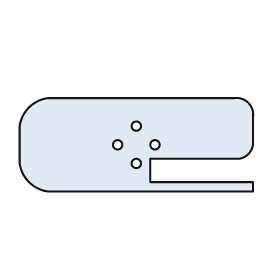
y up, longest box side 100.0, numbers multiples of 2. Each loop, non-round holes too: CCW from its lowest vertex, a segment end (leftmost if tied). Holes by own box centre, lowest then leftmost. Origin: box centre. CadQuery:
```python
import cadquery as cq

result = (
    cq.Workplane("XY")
    .moveTo(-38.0, -20.0)
    .lineTo(50.0, -20.0)
    .lineTo(50.0, -16.0)
    .lineTo(6.0, -16.0)
    .lineTo(6.0, -6.0)
    .lineTo(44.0, -6.0)
    .threePointArc((48.0, -4.0), (50.0, 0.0))
    .lineTo(50.0, 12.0)
    .threePointArc((48.0, 18.0), (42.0, 20.0))
    .lineTo(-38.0, 20.0)
    .threePointArc((-46.0, 16.0), (-50.0, 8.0))
    .lineTo(-50.0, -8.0)
    .threePointArc((-46.0, -16.0), (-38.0, -20.0))
    .close()
    .moveTo(0.0, -8.0)
    .circle(2.0)
    .moveTo(-8.0, 0.0)
    .circle(2.0)
    .moveTo(8.0, 0.0)
    .circle(2.0)
    .moveTo(0.0, 8.0)
    .circle(2.0)
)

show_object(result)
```